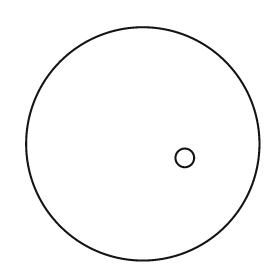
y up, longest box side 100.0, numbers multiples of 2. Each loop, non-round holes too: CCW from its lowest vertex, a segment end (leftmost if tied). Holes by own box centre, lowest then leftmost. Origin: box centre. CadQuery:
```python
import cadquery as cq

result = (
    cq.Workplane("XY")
    .moveTo(0.0, 0.0)
    .circle(50.0)
    .moveTo(18.0, -6.0)
    .circle(4.0)
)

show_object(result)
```